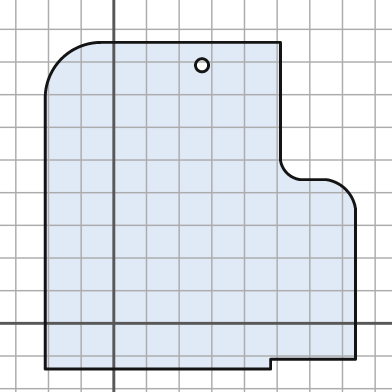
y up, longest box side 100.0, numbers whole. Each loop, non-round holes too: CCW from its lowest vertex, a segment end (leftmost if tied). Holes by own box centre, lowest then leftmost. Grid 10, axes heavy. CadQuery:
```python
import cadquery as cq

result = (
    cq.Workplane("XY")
    .moveTo(-21.0, -14.0)
    .lineTo(48.0, -14.0)
    .lineTo(48.0, -11.0)
    .lineTo(74.0, -11.0)
    .lineTo(74.0, 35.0)
    .threePointArc((71.0, 41.0), (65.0, 44.0))
    .lineTo(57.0, 44.0)
    .threePointArc((53.0, 46.0), (51.0, 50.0))
    .lineTo(51.0, 86.0)
    .lineTo(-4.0, 86.0)
    .threePointArc((-16.0, 81.0), (-21.0, 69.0))
    .close()
    .moveTo(27.0, 79.0)
    .circle(2.0)
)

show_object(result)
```